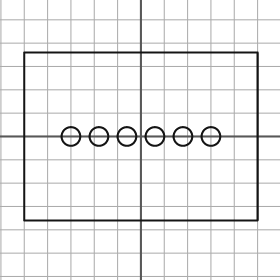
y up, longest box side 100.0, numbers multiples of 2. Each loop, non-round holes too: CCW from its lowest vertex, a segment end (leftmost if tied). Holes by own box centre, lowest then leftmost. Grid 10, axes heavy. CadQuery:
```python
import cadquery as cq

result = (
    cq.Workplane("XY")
    .moveTo(-50.0, -36.0)
    .lineTo(50.0, -36.0)
    .lineTo(50.0, 36.0)
    .lineTo(-50.0, 36.0)
    .close()
    .moveTo(-30.0, 0.0)
    .circle(4.0)
    .moveTo(-18.0, 0.0)
    .circle(4.0)
    .moveTo(-6.0, 0.0)
    .circle(4.0)
    .moveTo(6.0, 0.0)
    .circle(4.0)
    .moveTo(18.0, 0.0)
    .circle(4.0)
    .moveTo(30.0, 0.0)
    .circle(4.0)
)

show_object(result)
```